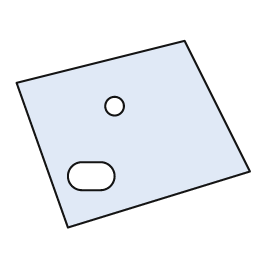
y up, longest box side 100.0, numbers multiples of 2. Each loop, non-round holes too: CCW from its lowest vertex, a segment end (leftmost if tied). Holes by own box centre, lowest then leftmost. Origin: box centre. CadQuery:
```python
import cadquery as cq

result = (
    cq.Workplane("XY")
    .moveTo(-28.0, -40.0)
    .lineTo(50.0, -16.0)
    .lineTo(22.0, 40.0)
    .lineTo(-50.0, 22.0)
    .close()
    .moveTo(-22.0, -24.0)
    .lineTo(-14.0, -24.0)
    .threePointArc((-8.0, -18.0), (-14.0, -12.0))
    .lineTo(-22.0, -12.0)
    .threePointArc((-28.0, -18.0), (-22.0, -24.0))
    .close()
    .moveTo(-8.0, 12.0)
    .circle(4.0)
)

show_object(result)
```